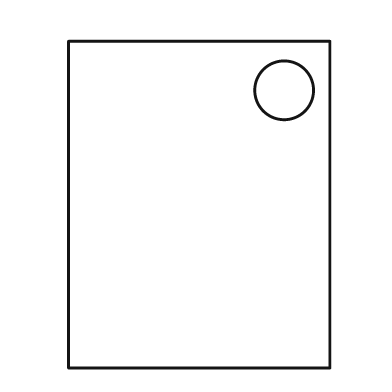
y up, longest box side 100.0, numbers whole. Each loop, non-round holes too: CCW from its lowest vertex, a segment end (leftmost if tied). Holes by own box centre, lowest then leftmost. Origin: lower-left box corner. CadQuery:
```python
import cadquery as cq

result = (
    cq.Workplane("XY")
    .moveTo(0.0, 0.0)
    .lineTo(80.0, 0.0)
    .lineTo(80.0, 100.0)
    .lineTo(0.0, 100.0)
    .close()
    .moveTo(66.0, 85.0)
    .circle(9.0)
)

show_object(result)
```